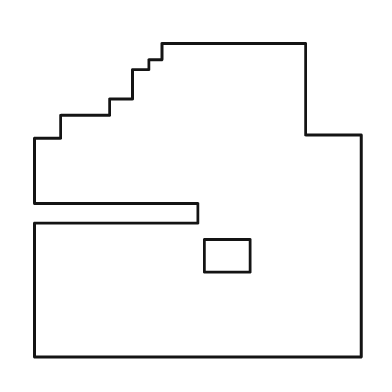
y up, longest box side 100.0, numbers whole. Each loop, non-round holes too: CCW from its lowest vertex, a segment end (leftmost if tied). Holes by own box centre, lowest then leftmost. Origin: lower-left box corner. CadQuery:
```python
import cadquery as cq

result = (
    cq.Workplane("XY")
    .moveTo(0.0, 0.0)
    .lineTo(100.0, 0.0)
    .lineTo(100.0, 68.0)
    .lineTo(83.0, 68.0)
    .lineTo(83.0, 96.0)
    .lineTo(39.0, 96.0)
    .lineTo(39.0, 91.0)
    .lineTo(35.0, 91.0)
    .lineTo(35.0, 88.0)
    .lineTo(30.0, 88.0)
    .lineTo(30.0, 79.0)
    .lineTo(23.0, 79.0)
    .lineTo(23.0, 74.0)
    .lineTo(8.0, 74.0)
    .lineTo(8.0, 67.0)
    .lineTo(0.0, 67.0)
    .lineTo(0.0, 47.0)
    .lineTo(50.0, 47.0)
    .lineTo(50.0, 41.0)
    .lineTo(0.0, 41.0)
    .close()
    .moveTo(52.0, 26.0)
    .lineTo(66.0, 26.0)
    .lineTo(66.0, 36.0)
    .lineTo(52.0, 36.0)
    .close()
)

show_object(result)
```